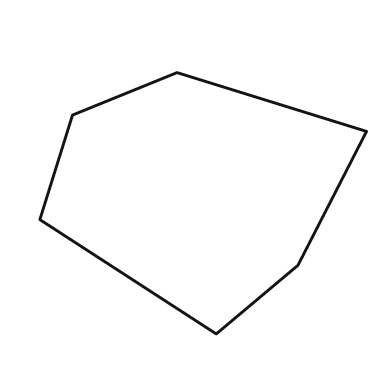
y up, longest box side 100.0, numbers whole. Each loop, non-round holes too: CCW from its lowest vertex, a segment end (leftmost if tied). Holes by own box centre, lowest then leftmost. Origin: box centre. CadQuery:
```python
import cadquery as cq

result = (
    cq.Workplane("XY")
    .moveTo(4.0, -40.0)
    .lineTo(29.0, -19.0)
    .lineTo(50.0, 22.0)
    .lineTo(-8.0, 40.0)
    .lineTo(-40.0, 27.0)
    .lineTo(-50.0, -5.0)
    .close()
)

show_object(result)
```